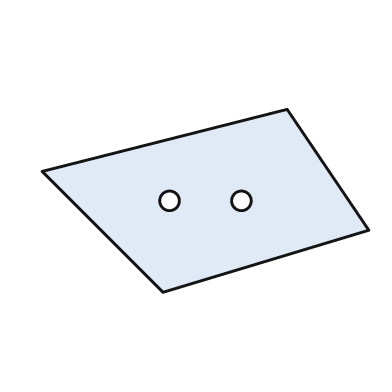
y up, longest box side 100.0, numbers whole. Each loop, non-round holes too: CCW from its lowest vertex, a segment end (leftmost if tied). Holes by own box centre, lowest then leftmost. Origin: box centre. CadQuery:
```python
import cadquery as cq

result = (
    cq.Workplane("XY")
    .moveTo(-13.0, -28.0)
    .lineTo(50.0, -9.0)
    .lineTo(25.0, 28.0)
    .lineTo(-50.0, 9.0)
    .close()
    .moveTo(-11.0, 0.0)
    .circle(3.0)
    .moveTo(11.0, 0.0)
    .circle(3.0)
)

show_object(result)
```